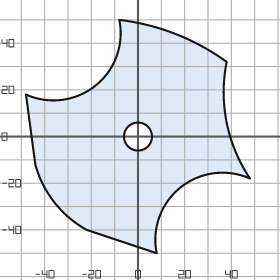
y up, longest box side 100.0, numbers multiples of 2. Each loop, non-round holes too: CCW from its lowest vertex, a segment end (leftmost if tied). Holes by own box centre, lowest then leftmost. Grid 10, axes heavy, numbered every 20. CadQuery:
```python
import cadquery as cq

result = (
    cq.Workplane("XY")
    .moveTo(8.0, -50.0)
    .threePointArc((18.0, -22.0), (48.0, -18.0))
    .threePointArc((38.0, 6.0), (38.0, 32.0))
    .threePointArc((16.0, 44.0), (-8.0, 50.0))
    .threePointArc((-18.0, 22.0), (-48.0, 18.0))
    .lineTo(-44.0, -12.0)
    .threePointArc((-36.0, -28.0), (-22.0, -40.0))
    .close()
    .moveTo(0.0, 0.0)
    .circle(6.0)
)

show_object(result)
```